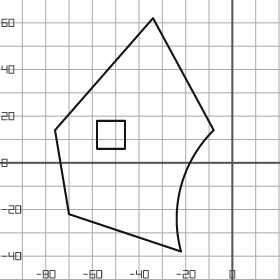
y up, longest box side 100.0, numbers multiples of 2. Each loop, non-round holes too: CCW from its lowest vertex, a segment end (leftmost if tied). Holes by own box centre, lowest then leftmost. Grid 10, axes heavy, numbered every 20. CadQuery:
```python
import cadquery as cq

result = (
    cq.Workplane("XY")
    .moveTo(-22.0, -38.0)
    .threePointArc((-22.0, -10.0), (-8.0, 14.0))
    .lineTo(-34.0, 62.0)
    .lineTo(-76.0, 14.0)
    .lineTo(-70.0, -22.0)
    .close()
    .moveTo(-58.0, 6.0)
    .lineTo(-46.0, 6.0)
    .lineTo(-46.0, 18.0)
    .lineTo(-58.0, 18.0)
    .close()
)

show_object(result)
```